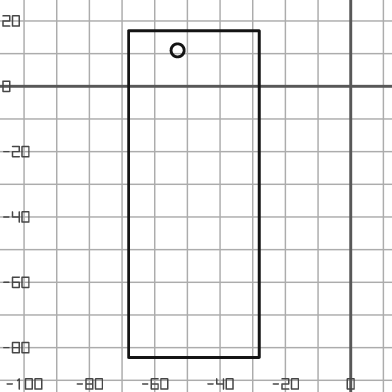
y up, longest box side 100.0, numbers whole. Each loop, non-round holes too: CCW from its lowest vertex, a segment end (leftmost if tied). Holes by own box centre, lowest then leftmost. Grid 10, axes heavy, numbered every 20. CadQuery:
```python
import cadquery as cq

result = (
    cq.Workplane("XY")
    .moveTo(-68.0, -83.0)
    .lineTo(-28.0, -83.0)
    .lineTo(-28.0, 17.0)
    .lineTo(-68.0, 17.0)
    .close()
    .moveTo(-53.0, 11.0)
    .circle(2.0)
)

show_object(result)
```